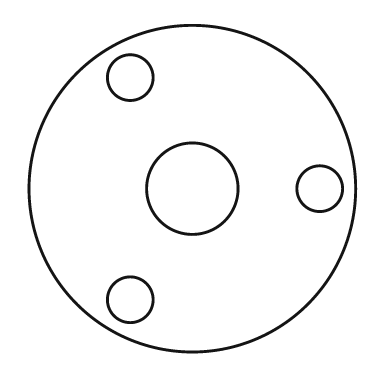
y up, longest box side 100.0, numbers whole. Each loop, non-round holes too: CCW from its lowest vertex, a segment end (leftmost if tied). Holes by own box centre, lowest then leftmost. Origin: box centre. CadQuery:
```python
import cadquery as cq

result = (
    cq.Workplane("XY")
    .moveTo(0.0, 0.0)
    .circle(50.0)
    .moveTo(-19.0, -34.0)
    .circle(7.0)
    .moveTo(0.0, 0.0)
    .circle(14.0)
    .moveTo(39.0, 0.0)
    .circle(7.0)
    .moveTo(-19.0, 34.0)
    .circle(7.0)
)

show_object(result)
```